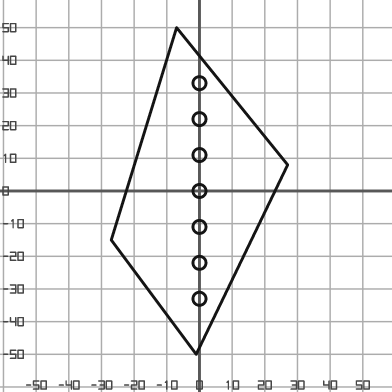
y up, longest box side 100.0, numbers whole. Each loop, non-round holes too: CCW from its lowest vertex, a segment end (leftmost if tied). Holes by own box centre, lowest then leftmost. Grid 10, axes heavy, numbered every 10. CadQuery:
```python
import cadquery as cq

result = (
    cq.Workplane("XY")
    .moveTo(-1.0, -50.0)
    .lineTo(27.0, 8.0)
    .lineTo(-7.0, 50.0)
    .lineTo(-27.0, -15.0)
    .close()
    .moveTo(0.0, -33.0)
    .circle(2.0)
    .moveTo(0.0, -22.0)
    .circle(2.0)
    .moveTo(0.0, -11.0)
    .circle(2.0)
    .moveTo(0.0, 0.0)
    .circle(2.0)
    .moveTo(0.0, 11.0)
    .circle(2.0)
    .moveTo(0.0, 22.0)
    .circle(2.0)
    .moveTo(0.0, 33.0)
    .circle(2.0)
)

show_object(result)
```